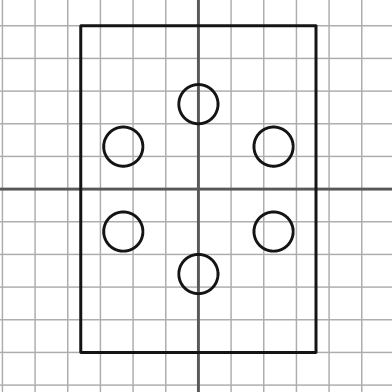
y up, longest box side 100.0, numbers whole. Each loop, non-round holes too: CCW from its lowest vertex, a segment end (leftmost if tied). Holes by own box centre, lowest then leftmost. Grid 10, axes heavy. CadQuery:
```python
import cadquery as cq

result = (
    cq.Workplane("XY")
    .moveTo(-36.0, -50.0)
    .lineTo(36.0, -50.0)
    .lineTo(36.0, 50.0)
    .lineTo(-36.0, 50.0)
    .close()
    .moveTo(0.0, -26.0)
    .circle(6.0)
    .moveTo(-23.0, -13.0)
    .circle(6.0)
    .moveTo(23.0, -13.0)
    .circle(6.0)
    .moveTo(-23.0, 13.0)
    .circle(6.0)
    .moveTo(23.0, 13.0)
    .circle(6.0)
    .moveTo(0.0, 26.0)
    .circle(6.0)
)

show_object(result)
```